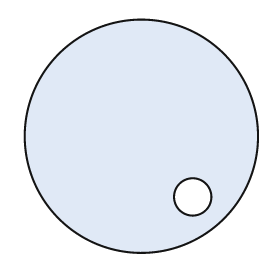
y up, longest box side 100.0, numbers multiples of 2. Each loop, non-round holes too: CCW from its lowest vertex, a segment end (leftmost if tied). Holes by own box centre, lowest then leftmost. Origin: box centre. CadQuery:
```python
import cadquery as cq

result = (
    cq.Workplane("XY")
    .moveTo(0.0, 0.0)
    .circle(50.0)
    .moveTo(22.0, -26.0)
    .circle(8.0)
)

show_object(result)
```